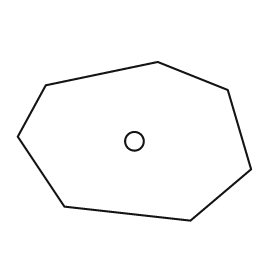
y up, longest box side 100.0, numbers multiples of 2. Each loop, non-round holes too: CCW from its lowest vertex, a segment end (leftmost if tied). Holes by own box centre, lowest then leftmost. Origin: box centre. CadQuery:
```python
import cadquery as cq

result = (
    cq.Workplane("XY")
    .moveTo(24.0, -34.0)
    .lineTo(50.0, -12.0)
    .lineTo(40.0, 22.0)
    .lineTo(10.0, 34.0)
    .lineTo(-38.0, 24.0)
    .lineTo(-50.0, 2.0)
    .lineTo(-30.0, -28.0)
    .close()
    .moveTo(0.0, 0.0)
    .circle(4.0)
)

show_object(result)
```